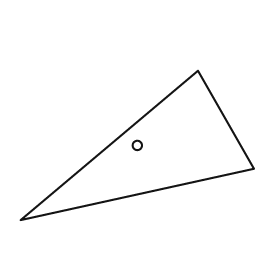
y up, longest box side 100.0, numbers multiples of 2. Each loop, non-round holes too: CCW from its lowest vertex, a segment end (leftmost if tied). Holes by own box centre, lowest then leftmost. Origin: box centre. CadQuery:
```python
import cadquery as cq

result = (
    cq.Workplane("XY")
    .moveTo(-50.0, -32.0)
    .lineTo(50.0, -10.0)
    .lineTo(26.0, 32.0)
    .close()
    .moveTo(0.0, 0.0)
    .circle(2.0)
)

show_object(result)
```